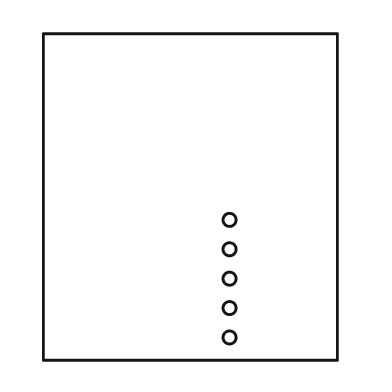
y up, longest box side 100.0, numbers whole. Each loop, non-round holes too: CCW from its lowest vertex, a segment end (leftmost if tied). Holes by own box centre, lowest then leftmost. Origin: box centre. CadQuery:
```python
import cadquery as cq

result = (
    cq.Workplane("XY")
    .moveTo(-45.0, -50.0)
    .lineTo(45.0, -50.0)
    .lineTo(45.0, 50.0)
    .lineTo(-45.0, 50.0)
    .close()
    .moveTo(12.0, -43.0)
    .circle(2.0)
    .moveTo(12.0, -34.0)
    .circle(2.0)
    .moveTo(12.0, -25.0)
    .circle(2.0)
    .moveTo(12.0, -16.0)
    .circle(2.0)
    .moveTo(12.0, -7.0)
    .circle(2.0)
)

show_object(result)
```